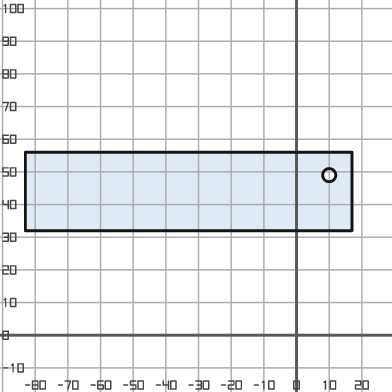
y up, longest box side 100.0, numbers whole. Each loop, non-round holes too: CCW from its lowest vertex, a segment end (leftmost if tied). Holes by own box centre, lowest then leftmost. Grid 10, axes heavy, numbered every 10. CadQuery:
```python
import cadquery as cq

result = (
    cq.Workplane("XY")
    .moveTo(-83.0, 32.0)
    .lineTo(17.0, 32.0)
    .lineTo(17.0, 56.0)
    .lineTo(-83.0, 56.0)
    .close()
    .moveTo(10.0, 49.0)
    .circle(2.0)
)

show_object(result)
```